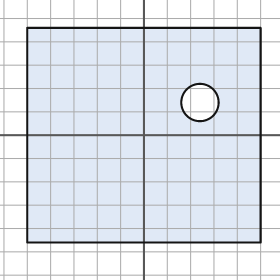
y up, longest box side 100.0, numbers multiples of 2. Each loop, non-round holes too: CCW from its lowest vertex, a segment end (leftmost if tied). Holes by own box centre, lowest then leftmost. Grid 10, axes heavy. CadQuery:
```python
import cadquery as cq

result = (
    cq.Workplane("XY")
    .moveTo(-50.0, -46.0)
    .lineTo(50.0, -46.0)
    .lineTo(50.0, 46.0)
    .lineTo(-50.0, 46.0)
    .close()
    .moveTo(24.0, 14.0)
    .circle(8.0)
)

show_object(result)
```